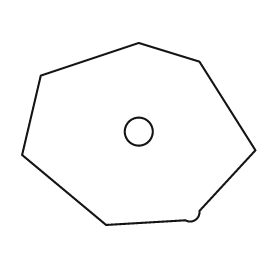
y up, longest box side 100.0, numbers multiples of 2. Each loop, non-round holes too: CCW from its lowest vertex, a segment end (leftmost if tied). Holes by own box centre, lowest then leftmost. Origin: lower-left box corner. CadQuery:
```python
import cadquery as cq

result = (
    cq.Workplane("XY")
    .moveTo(36.0, 0.0)
    .lineTo(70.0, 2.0)
    .threePointArc((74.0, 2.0), (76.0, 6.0))
    .lineTo(100.0, 32.0)
    .lineTo(76.0, 70.0)
    .lineTo(50.0, 78.0)
    .lineTo(8.0, 64.0)
    .lineTo(0.0, 30.0)
    .close()
    .moveTo(50.0, 40.0)
    .circle(6.0)
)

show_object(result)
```